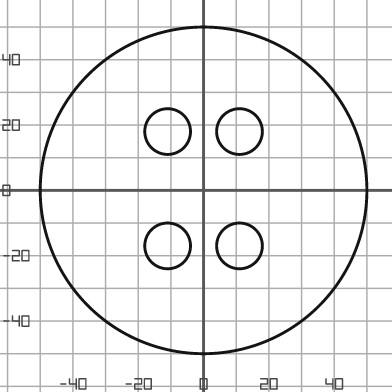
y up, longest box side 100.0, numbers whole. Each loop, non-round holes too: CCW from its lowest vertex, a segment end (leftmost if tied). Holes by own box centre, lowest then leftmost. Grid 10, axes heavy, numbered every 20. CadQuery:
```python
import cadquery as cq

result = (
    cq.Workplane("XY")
    .moveTo(0.0, 0.0)
    .circle(50.0)
    .moveTo(-11.0, -17.0)
    .circle(7.0)
    .moveTo(11.0, -17.0)
    .circle(7.0)
    .moveTo(-11.0, 18.0)
    .circle(7.0)
    .moveTo(11.0, 18.0)
    .circle(7.0)
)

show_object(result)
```